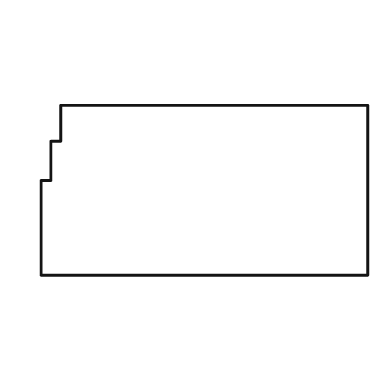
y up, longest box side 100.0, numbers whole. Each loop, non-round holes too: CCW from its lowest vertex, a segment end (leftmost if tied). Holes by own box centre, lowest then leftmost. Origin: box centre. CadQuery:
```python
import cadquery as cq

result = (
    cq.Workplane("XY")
    .moveTo(-50.0, -26.0)
    .lineTo(50.0, -26.0)
    .lineTo(50.0, 26.0)
    .lineTo(-44.0, 26.0)
    .lineTo(-44.0, 15.0)
    .lineTo(-47.0, 15.0)
    .lineTo(-47.0, 3.0)
    .lineTo(-50.0, 3.0)
    .close()
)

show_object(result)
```